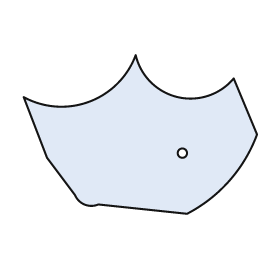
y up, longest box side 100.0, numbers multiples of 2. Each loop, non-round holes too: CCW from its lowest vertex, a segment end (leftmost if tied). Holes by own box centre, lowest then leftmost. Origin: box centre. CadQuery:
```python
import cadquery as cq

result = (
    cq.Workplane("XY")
    .moveTo(20.0, -34.0)
    .threePointArc((38.0, -20.0), (50.0, 0.0))
    .lineTo(40.0, 24.0)
    .threePointArc((16.0, 16.0), (-2.0, 34.0))
    .threePointArc((-22.0, 14.0), (-50.0, 16.0))
    .lineTo(-40.0, -10.0)
    .lineTo(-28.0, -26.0)
    .threePointArc((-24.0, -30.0), (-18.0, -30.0))
    .close()
    .moveTo(18.0, -8.0)
    .circle(2.0)
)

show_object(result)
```